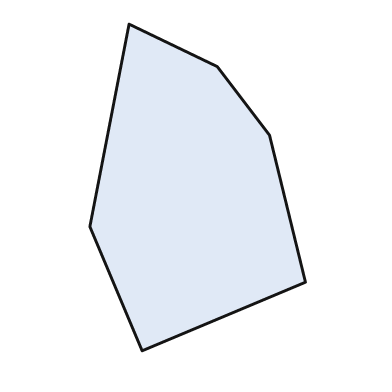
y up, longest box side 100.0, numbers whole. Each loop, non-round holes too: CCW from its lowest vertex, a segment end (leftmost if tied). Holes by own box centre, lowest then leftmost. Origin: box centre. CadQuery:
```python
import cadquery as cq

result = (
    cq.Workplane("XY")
    .moveTo(-17.0, -50.0)
    .lineTo(33.0, -29.0)
    .lineTo(22.0, 16.0)
    .lineTo(6.0, 37.0)
    .lineTo(-21.0, 50.0)
    .lineTo(-33.0, -12.0)
    .close()
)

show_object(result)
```